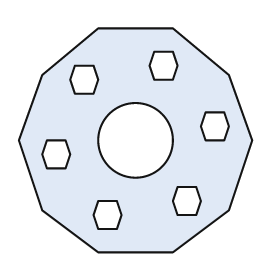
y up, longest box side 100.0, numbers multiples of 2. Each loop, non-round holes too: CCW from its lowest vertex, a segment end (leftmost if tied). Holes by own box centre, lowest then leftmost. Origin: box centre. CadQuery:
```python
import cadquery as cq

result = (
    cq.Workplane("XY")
    .moveTo(-16.0, -48.0)
    .lineTo(16.0, -48.0)
    .lineTo(40.0, -30.0)
    .lineTo(50.0, 0.0)
    .lineTo(40.0, 28.0)
    .lineTo(16.0, 48.0)
    .lineTo(-16.0, 48.0)
    .lineTo(-40.0, 28.0)
    .lineTo(-50.0, 0.0)
    .lineTo(-40.0, -30.0)
    .close()
    .moveTo(-16.0, -38.0)
    .lineTo(-8.0, -38.0)
    .lineTo(-6.0, -32.0)
    .lineTo(-8.0, -26.0)
    .lineTo(-16.0, -26.0)
    .lineTo(-18.0, -32.0)
    .close()
    .moveTo(18.0, -32.0)
    .lineTo(26.0, -32.0)
    .lineTo(28.0, -26.0)
    .lineTo(26.0, -20.0)
    .lineTo(18.0, -20.0)
    .lineTo(16.0, -26.0)
    .close()
    .moveTo(-38.0, -12.0)
    .lineTo(-30.0, -12.0)
    .lineTo(-28.0, -6.0)
    .lineTo(-30.0, 0.0)
    .lineTo(-38.0, 0.0)
    .lineTo(-40.0, -6.0)
    .close()
    .moveTo(0.0, 0.0)
    .circle(16.0)
    .moveTo(30.0, 0.0)
    .lineTo(38.0, 0.0)
    .lineTo(40.0, 6.0)
    .lineTo(38.0, 12.0)
    .lineTo(30.0, 12.0)
    .lineTo(28.0, 6.0)
    .close()
    .moveTo(-26.0, 20.0)
    .lineTo(-18.0, 20.0)
    .lineTo(-16.0, 26.0)
    .lineTo(-18.0, 32.0)
    .lineTo(-26.0, 32.0)
    .lineTo(-28.0, 26.0)
    .close()
    .moveTo(8.0, 26.0)
    .lineTo(16.0, 26.0)
    .lineTo(18.0, 32.0)
    .lineTo(16.0, 38.0)
    .lineTo(8.0, 38.0)
    .lineTo(6.0, 32.0)
    .close()
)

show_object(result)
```